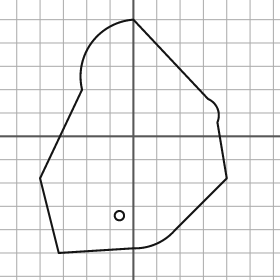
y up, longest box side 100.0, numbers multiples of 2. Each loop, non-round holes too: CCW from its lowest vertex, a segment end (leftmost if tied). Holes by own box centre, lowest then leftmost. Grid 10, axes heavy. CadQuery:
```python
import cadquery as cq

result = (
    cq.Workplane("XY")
    .moveTo(-32.0, -50.0)
    .lineTo(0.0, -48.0)
    .threePointArc((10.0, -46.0), (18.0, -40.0))
    .lineTo(40.0, -18.0)
    .lineTo(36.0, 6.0)
    .threePointArc((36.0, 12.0), (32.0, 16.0))
    .lineTo(0.0, 50.0)
    .threePointArc((-18.0, 40.0), (-22.0, 20.0))
    .lineTo(-40.0, -18.0)
    .close()
    .moveTo(-6.0, -34.0)
    .circle(2.0)
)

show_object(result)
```